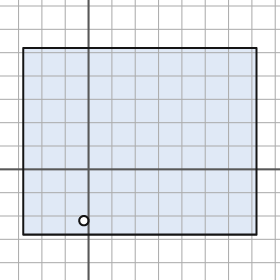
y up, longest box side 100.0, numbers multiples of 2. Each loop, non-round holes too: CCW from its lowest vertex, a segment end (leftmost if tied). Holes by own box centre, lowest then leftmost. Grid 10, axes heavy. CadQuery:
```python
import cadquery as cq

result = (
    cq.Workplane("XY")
    .moveTo(-28.0, -28.0)
    .lineTo(72.0, -28.0)
    .lineTo(72.0, 52.0)
    .lineTo(-28.0, 52.0)
    .close()
    .moveTo(-2.0, -22.0)
    .circle(2.0)
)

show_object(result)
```